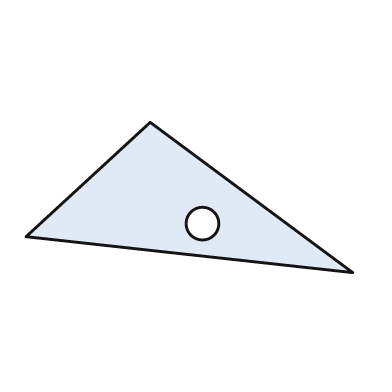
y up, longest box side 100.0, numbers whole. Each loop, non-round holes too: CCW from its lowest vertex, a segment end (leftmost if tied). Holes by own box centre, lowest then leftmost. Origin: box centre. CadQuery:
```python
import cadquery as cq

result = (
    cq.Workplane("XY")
    .moveTo(50.0, -23.0)
    .lineTo(-12.0, 23.0)
    .lineTo(-50.0, -12.0)
    .close()
    .moveTo(4.0, -8.0)
    .circle(5.0)
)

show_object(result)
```